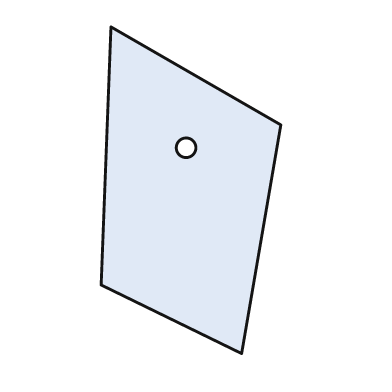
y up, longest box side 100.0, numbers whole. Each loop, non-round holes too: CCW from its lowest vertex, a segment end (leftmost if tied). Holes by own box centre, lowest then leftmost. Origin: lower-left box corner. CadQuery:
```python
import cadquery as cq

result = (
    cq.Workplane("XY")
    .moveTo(43.0, 0.0)
    .lineTo(55.0, 70.0)
    .lineTo(3.0, 100.0)
    .lineTo(0.0, 21.0)
    .close()
    .moveTo(26.0, 63.0)
    .circle(3.0)
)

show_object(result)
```